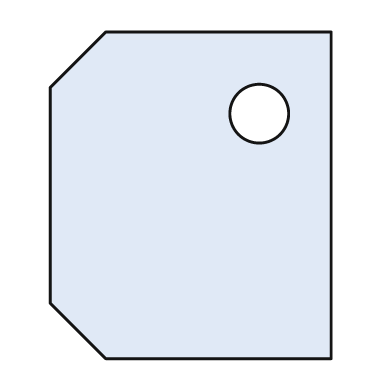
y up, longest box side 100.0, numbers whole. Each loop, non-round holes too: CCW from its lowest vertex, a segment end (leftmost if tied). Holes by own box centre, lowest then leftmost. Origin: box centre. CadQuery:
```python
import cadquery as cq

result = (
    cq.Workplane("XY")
    .moveTo(-26.0, -50.0)
    .lineTo(43.0, -50.0)
    .lineTo(43.0, 50.0)
    .lineTo(-26.0, 50.0)
    .lineTo(-43.0, 33.0)
    .lineTo(-43.0, -33.0)
    .close()
    .moveTo(21.0, 25.0)
    .circle(9.0)
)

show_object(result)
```